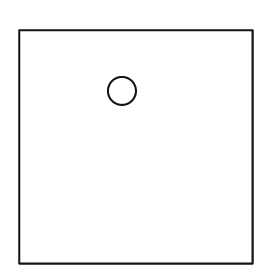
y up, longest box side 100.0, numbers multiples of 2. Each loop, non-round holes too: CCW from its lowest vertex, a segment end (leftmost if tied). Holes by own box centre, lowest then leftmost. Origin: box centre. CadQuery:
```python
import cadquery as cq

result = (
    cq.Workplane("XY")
    .moveTo(-50.0, -50.0)
    .lineTo(50.0, -50.0)
    .lineTo(50.0, 50.0)
    .lineTo(-50.0, 50.0)
    .close()
    .moveTo(-6.0, 24.0)
    .circle(6.0)
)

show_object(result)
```